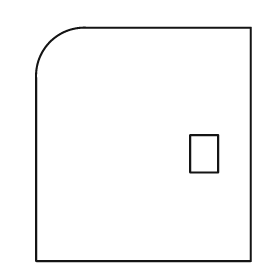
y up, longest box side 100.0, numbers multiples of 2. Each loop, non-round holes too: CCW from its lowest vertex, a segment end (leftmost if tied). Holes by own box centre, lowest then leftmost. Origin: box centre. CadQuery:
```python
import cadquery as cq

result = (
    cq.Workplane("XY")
    .moveTo(-46.0, -50.0)
    .lineTo(46.0, -50.0)
    .lineTo(46.0, 50.0)
    .lineTo(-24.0, 50.0)
    .threePointArc((-40.0, 44.0), (-46.0, 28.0))
    .close()
    .moveTo(20.0, -12.0)
    .lineTo(32.0, -12.0)
    .lineTo(32.0, 4.0)
    .lineTo(20.0, 4.0)
    .close()
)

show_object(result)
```